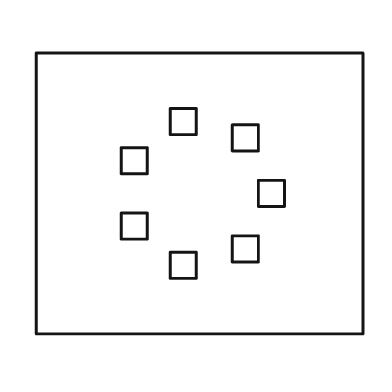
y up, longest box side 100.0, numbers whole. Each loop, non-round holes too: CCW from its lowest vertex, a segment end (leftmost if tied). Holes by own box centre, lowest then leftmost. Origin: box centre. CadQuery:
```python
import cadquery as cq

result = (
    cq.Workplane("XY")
    .moveTo(-50.0, -43.0)
    .lineTo(50.0, -43.0)
    .lineTo(50.0, 43.0)
    .lineTo(-50.0, 43.0)
    .close()
    .moveTo(-9.0, -26.0)
    .lineTo(-1.0, -26.0)
    .lineTo(-1.0, -18.0)
    .lineTo(-9.0, -18.0)
    .close()
    .moveTo(10.0, -21.0)
    .lineTo(18.0, -21.0)
    .lineTo(18.0, -13.0)
    .lineTo(10.0, -13.0)
    .close()
    .moveTo(-24.0, -14.0)
    .lineTo(-16.0, -14.0)
    .lineTo(-16.0, -6.0)
    .lineTo(-24.0, -6.0)
    .close()
    .moveTo(18.0, -4.0)
    .lineTo(26.0, -4.0)
    .lineTo(26.0, 4.0)
    .lineTo(18.0, 4.0)
    .close()
    .moveTo(-24.0, 6.0)
    .lineTo(-16.0, 6.0)
    .lineTo(-16.0, 14.0)
    .lineTo(-24.0, 14.0)
    .close()
    .moveTo(10.0, 13.0)
    .lineTo(18.0, 13.0)
    .lineTo(18.0, 21.0)
    .lineTo(10.0, 21.0)
    .close()
    .moveTo(-9.0, 18.0)
    .lineTo(-1.0, 18.0)
    .lineTo(-1.0, 26.0)
    .lineTo(-9.0, 26.0)
    .close()
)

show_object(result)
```